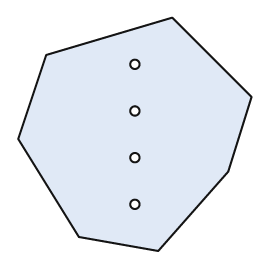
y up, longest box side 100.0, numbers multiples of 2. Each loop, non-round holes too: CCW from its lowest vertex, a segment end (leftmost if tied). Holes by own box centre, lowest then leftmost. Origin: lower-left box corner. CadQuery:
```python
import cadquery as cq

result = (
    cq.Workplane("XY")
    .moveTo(60.0, 0.0)
    .lineTo(90.0, 34.0)
    .lineTo(100.0, 66.0)
    .lineTo(66.0, 100.0)
    .lineTo(12.0, 84.0)
    .lineTo(0.0, 48.0)
    .lineTo(26.0, 6.0)
    .close()
    .moveTo(50.0, 20.0)
    .circle(2.0)
    .moveTo(50.0, 40.0)
    .circle(2.0)
    .moveTo(50.0, 60.0)
    .circle(2.0)
    .moveTo(50.0, 80.0)
    .circle(2.0)
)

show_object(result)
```